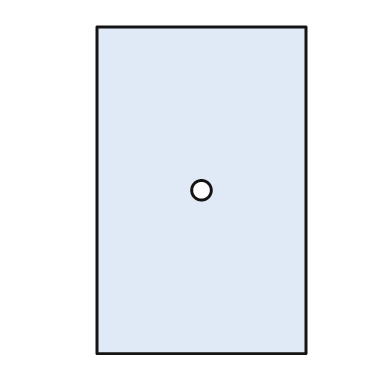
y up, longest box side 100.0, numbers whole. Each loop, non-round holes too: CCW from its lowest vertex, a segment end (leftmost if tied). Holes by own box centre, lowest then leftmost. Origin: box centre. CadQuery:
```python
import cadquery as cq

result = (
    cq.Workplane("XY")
    .moveTo(-32.0, -50.0)
    .lineTo(32.0, -50.0)
    .lineTo(32.0, 50.0)
    .lineTo(-32.0, 50.0)
    .close()
    .moveTo(0.0, 0.0)
    .circle(3.0)
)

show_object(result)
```